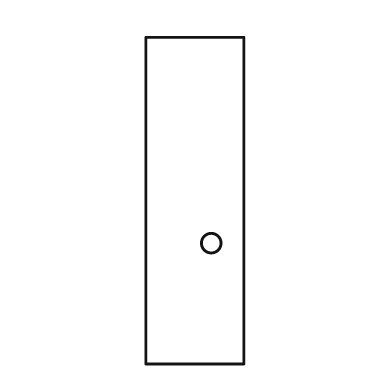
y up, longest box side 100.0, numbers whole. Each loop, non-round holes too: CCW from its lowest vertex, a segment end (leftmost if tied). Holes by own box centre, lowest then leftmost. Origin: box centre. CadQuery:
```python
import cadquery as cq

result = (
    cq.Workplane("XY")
    .moveTo(-15.0, -50.0)
    .lineTo(15.0, -50.0)
    .lineTo(15.0, 50.0)
    .lineTo(-15.0, 50.0)
    .close()
    .moveTo(5.0, -13.0)
    .circle(3.0)
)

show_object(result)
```